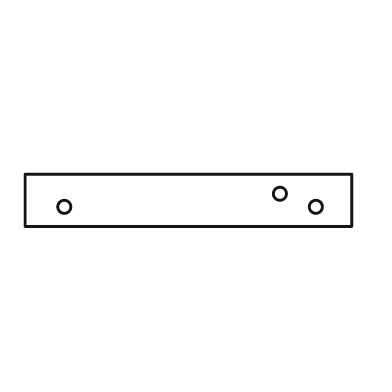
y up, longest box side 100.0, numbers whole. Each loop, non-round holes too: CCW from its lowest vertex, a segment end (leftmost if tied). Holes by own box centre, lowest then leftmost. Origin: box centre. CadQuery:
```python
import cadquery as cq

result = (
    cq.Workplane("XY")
    .moveTo(-50.0, -8.0)
    .lineTo(50.0, -8.0)
    .lineTo(50.0, 8.0)
    .lineTo(-50.0, 8.0)
    .close()
    .moveTo(-38.0, -2.0)
    .circle(2.0)
    .moveTo(39.0, -2.0)
    .circle(2.0)
    .moveTo(28.0, 2.0)
    .circle(2.0)
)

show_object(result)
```